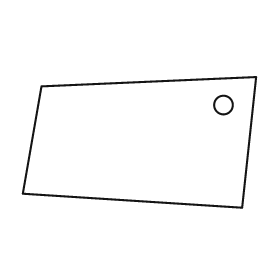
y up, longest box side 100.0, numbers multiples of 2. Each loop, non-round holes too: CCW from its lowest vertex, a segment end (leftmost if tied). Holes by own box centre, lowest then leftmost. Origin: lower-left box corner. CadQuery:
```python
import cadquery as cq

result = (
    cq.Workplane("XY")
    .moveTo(94.0, 0.0)
    .lineTo(100.0, 56.0)
    .lineTo(8.0, 52.0)
    .lineTo(0.0, 6.0)
    .close()
    .moveTo(86.0, 44.0)
    .circle(4.0)
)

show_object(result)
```